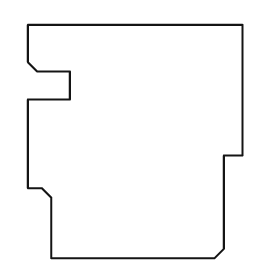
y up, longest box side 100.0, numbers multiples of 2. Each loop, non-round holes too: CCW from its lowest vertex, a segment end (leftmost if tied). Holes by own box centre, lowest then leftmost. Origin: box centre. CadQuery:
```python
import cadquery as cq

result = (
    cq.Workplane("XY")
    .moveTo(-36.0, -50.0)
    .lineTo(34.0, -50.0)
    .lineTo(38.0, -46.0)
    .lineTo(38.0, -6.0)
    .lineTo(46.0, -6.0)
    .lineTo(46.0, 50.0)
    .lineTo(-46.0, 50.0)
    .lineTo(-46.0, 34.0)
    .lineTo(-42.0, 30.0)
    .lineTo(-28.0, 30.0)
    .lineTo(-28.0, 18.0)
    .lineTo(-46.0, 18.0)
    .lineTo(-46.0, -20.0)
    .lineTo(-40.0, -20.0)
    .lineTo(-36.0, -24.0)
    .close()
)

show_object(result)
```